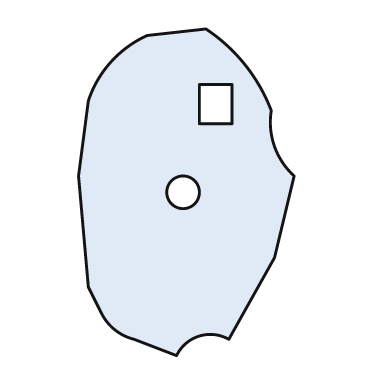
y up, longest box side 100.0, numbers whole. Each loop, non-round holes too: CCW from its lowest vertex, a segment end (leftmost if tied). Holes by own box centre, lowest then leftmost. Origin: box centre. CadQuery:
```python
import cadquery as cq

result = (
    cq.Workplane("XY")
    .moveTo(-3.0, -50.0)
    .threePointArc((4.0, -44.0), (13.0, -45.0))
    .lineTo(27.0, -20.0)
    .lineTo(33.0, 5.0)
    .threePointArc((27.0, 14.0), (26.0, 25.0))
    .threePointArc((18.0, 39.0), (6.0, 50.0))
    .lineTo(-12.0, 48.0)
    .threePointArc((-23.0, 40.0), (-30.0, 28.0))
    .lineTo(-33.0, 5.0)
    .lineTo(-30.0, -29.0)
    .lineTo(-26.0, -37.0)
    .threePointArc((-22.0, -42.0), (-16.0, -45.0))
    .close()
    .moveTo(-1.0, 0.0)
    .circle(5.0)
    .moveTo(4.0, 21.0)
    .lineTo(14.0, 21.0)
    .lineTo(14.0, 33.0)
    .lineTo(4.0, 33.0)
    .close()
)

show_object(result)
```